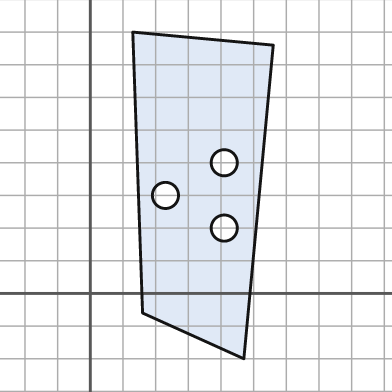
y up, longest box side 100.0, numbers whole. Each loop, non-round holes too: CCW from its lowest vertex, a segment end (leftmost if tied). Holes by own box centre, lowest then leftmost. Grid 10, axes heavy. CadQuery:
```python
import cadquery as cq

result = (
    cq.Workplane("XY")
    .moveTo(47.0, -20.0)
    .lineTo(56.0, 76.0)
    .lineTo(13.0, 80.0)
    .lineTo(16.0, -6.0)
    .close()
    .moveTo(41.0, 20.0)
    .circle(4.0)
    .moveTo(23.0, 30.0)
    .circle(4.0)
    .moveTo(41.0, 40.0)
    .circle(4.0)
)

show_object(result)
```